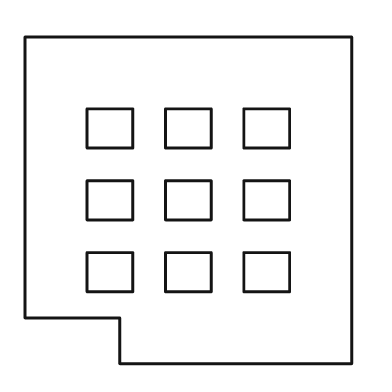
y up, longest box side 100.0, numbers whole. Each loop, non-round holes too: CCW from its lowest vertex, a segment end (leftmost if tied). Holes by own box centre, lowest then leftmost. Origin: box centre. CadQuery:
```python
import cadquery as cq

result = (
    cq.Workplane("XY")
    .moveTo(-21.0, -50.0)
    .lineTo(50.0, -50.0)
    .lineTo(50.0, 50.0)
    .lineTo(-50.0, 50.0)
    .lineTo(-50.0, -36.0)
    .lineTo(-21.0, -36.0)
    .close()
    .moveTo(-31.0, -28.0)
    .lineTo(-17.0, -28.0)
    .lineTo(-17.0, -16.0)
    .lineTo(-31.0, -16.0)
    .close()
    .moveTo(-7.0, -28.0)
    .lineTo(7.0, -28.0)
    .lineTo(7.0, -16.0)
    .lineTo(-7.0, -16.0)
    .close()
    .moveTo(17.0, -28.0)
    .lineTo(31.0, -28.0)
    .lineTo(31.0, -16.0)
    .lineTo(17.0, -16.0)
    .close()
    .moveTo(-31.0, -6.0)
    .lineTo(-17.0, -6.0)
    .lineTo(-17.0, 6.0)
    .lineTo(-31.0, 6.0)
    .close()
    .moveTo(-7.0, -6.0)
    .lineTo(7.0, -6.0)
    .lineTo(7.0, 6.0)
    .lineTo(-7.0, 6.0)
    .close()
    .moveTo(17.0, -6.0)
    .lineTo(31.0, -6.0)
    .lineTo(31.0, 6.0)
    .lineTo(17.0, 6.0)
    .close()
    .moveTo(-31.0, 16.0)
    .lineTo(-17.0, 16.0)
    .lineTo(-17.0, 28.0)
    .lineTo(-31.0, 28.0)
    .close()
    .moveTo(-7.0, 16.0)
    .lineTo(7.0, 16.0)
    .lineTo(7.0, 28.0)
    .lineTo(-7.0, 28.0)
    .close()
    .moveTo(17.0, 16.0)
    .lineTo(31.0, 16.0)
    .lineTo(31.0, 28.0)
    .lineTo(17.0, 28.0)
    .close()
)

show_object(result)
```